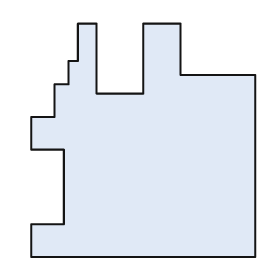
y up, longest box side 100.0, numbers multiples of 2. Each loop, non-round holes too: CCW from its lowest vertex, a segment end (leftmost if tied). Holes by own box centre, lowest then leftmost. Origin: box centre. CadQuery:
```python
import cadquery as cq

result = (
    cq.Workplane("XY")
    .moveTo(-48.0, -50.0)
    .lineTo(48.0, -50.0)
    .lineTo(48.0, 28.0)
    .lineTo(16.0, 28.0)
    .lineTo(16.0, 50.0)
    .lineTo(0.0, 50.0)
    .lineTo(0.0, 20.0)
    .lineTo(-20.0, 20.0)
    .lineTo(-20.0, 50.0)
    .lineTo(-28.0, 50.0)
    .lineTo(-28.0, 34.0)
    .lineTo(-32.0, 34.0)
    .lineTo(-32.0, 24.0)
    .lineTo(-38.0, 24.0)
    .lineTo(-38.0, 10.0)
    .lineTo(-48.0, 10.0)
    .lineTo(-48.0, -4.0)
    .lineTo(-34.0, -4.0)
    .lineTo(-34.0, -36.0)
    .lineTo(-48.0, -36.0)
    .close()
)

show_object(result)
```